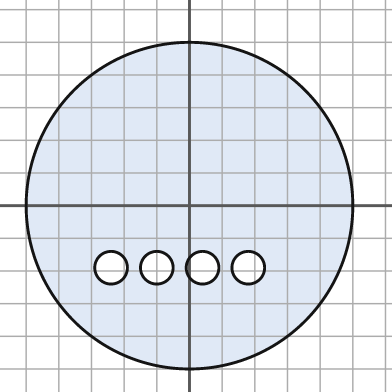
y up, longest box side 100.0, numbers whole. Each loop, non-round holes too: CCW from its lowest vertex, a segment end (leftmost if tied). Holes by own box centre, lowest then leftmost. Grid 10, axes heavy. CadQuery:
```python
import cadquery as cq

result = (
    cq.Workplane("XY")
    .moveTo(0.0, 0.0)
    .circle(50.0)
    .moveTo(-24.0, -19.0)
    .circle(5.0)
    .moveTo(-10.0, -19.0)
    .circle(5.0)
    .moveTo(4.0, -19.0)
    .circle(5.0)
    .moveTo(18.0, -19.0)
    .circle(5.0)
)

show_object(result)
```